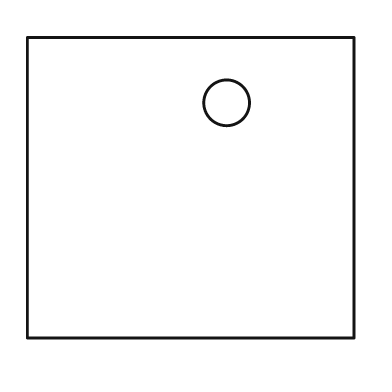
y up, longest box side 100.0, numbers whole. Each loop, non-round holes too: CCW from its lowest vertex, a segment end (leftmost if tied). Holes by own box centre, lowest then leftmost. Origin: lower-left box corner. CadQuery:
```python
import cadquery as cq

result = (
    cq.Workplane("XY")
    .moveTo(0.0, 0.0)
    .lineTo(100.0, 0.0)
    .lineTo(100.0, 92.0)
    .lineTo(0.0, 92.0)
    .close()
    .moveTo(61.0, 72.0)
    .circle(7.0)
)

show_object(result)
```